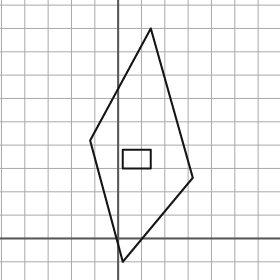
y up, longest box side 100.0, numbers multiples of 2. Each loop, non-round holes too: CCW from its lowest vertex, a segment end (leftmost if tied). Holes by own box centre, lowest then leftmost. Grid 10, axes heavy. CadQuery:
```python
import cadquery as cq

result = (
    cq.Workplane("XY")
    .moveTo(2.0, -10.0)
    .lineTo(32.0, 26.0)
    .lineTo(14.0, 90.0)
    .lineTo(-12.0, 42.0)
    .close()
    .moveTo(2.0, 30.0)
    .lineTo(14.0, 30.0)
    .lineTo(14.0, 38.0)
    .lineTo(2.0, 38.0)
    .close()
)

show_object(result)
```